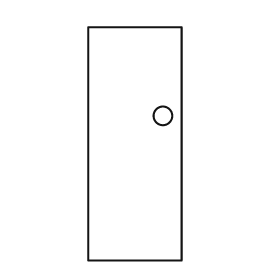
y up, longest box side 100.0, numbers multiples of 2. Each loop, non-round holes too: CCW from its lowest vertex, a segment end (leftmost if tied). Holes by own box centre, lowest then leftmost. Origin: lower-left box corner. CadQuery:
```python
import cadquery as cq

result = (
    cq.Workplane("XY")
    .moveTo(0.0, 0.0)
    .lineTo(40.0, 0.0)
    .lineTo(40.0, 100.0)
    .lineTo(0.0, 100.0)
    .close()
    .moveTo(32.0, 62.0)
    .circle(4.0)
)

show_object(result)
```